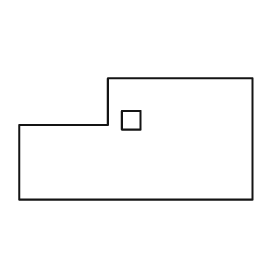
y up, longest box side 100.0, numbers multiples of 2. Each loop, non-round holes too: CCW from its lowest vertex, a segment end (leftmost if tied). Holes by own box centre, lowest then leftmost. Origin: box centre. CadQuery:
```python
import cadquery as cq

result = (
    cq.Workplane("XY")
    .moveTo(-50.0, -26.0)
    .lineTo(50.0, -26.0)
    .lineTo(50.0, 26.0)
    .lineTo(-12.0, 26.0)
    .lineTo(-12.0, 6.0)
    .lineTo(-50.0, 6.0)
    .close()
    .moveTo(-6.0, 4.0)
    .lineTo(2.0, 4.0)
    .lineTo(2.0, 12.0)
    .lineTo(-6.0, 12.0)
    .close()
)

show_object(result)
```